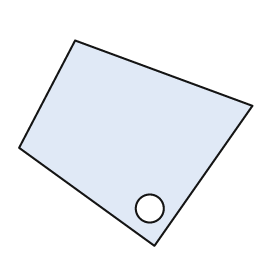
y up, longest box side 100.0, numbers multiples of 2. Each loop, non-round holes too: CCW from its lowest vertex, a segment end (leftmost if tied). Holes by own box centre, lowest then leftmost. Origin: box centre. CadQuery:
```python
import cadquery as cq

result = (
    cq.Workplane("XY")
    .moveTo(8.0, -44.0)
    .lineTo(50.0, 16.0)
    .lineTo(-26.0, 44.0)
    .lineTo(-50.0, -2.0)
    .close()
    .moveTo(6.0, -28.0)
    .circle(6.0)
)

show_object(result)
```